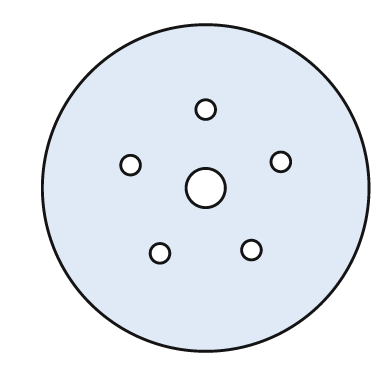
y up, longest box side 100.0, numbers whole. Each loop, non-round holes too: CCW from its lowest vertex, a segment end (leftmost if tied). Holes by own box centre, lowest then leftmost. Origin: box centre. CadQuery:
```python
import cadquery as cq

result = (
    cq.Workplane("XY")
    .moveTo(0.0, 0.0)
    .circle(50.0)
    .moveTo(-14.0, -20.0)
    .circle(3.0)
    .moveTo(14.0, -19.0)
    .circle(3.0)
    .moveTo(0.0, 0.0)
    .circle(6.0)
    .moveTo(-23.0, 7.0)
    .circle(3.0)
    .moveTo(23.0, 8.0)
    .circle(3.0)
    .moveTo(0.0, 24.0)
    .circle(3.0)
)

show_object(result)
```